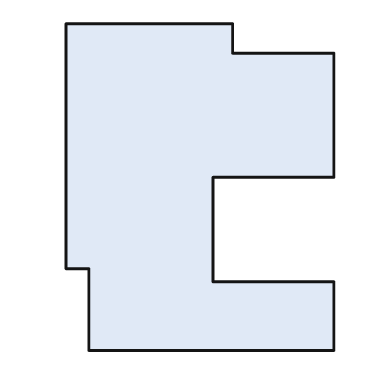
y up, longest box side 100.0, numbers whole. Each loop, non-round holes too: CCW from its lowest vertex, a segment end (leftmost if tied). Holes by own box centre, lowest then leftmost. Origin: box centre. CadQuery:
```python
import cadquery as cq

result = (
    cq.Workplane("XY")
    .moveTo(-34.0, -50.0)
    .lineTo(41.0, -50.0)
    .lineTo(41.0, -29.0)
    .lineTo(4.0, -29.0)
    .lineTo(4.0, 3.0)
    .lineTo(41.0, 3.0)
    .lineTo(41.0, 41.0)
    .lineTo(10.0, 41.0)
    .lineTo(10.0, 50.0)
    .lineTo(-41.0, 50.0)
    .lineTo(-41.0, -25.0)
    .lineTo(-34.0, -25.0)
    .close()
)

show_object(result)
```